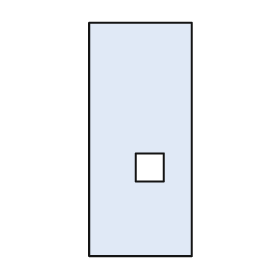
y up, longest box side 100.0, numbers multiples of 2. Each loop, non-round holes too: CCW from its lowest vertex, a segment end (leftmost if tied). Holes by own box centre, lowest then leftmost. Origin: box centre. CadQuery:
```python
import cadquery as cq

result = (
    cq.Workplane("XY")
    .moveTo(-22.0, -50.0)
    .lineTo(22.0, -50.0)
    .lineTo(22.0, 50.0)
    .lineTo(-22.0, 50.0)
    .close()
    .moveTo(-2.0, -18.0)
    .lineTo(10.0, -18.0)
    .lineTo(10.0, -6.0)
    .lineTo(-2.0, -6.0)
    .close()
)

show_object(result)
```